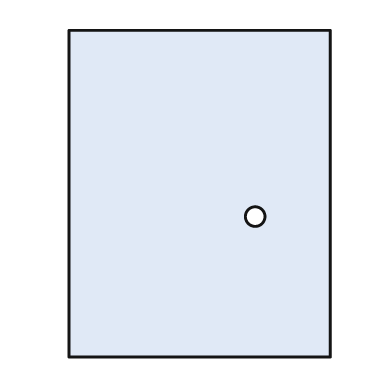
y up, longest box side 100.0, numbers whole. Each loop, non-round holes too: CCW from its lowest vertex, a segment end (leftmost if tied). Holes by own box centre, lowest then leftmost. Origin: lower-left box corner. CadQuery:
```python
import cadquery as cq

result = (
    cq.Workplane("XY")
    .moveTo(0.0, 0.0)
    .lineTo(80.0, 0.0)
    .lineTo(80.0, 100.0)
    .lineTo(0.0, 100.0)
    .close()
    .moveTo(57.0, 43.0)
    .circle(3.0)
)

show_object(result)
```